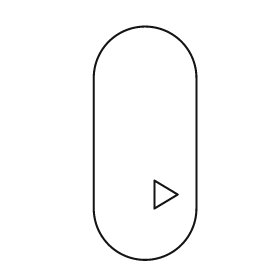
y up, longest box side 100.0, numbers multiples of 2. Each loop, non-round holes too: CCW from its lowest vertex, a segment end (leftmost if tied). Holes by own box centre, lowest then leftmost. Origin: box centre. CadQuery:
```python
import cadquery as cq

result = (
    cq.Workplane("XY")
    .moveTo(-22.0, -28.0)
    .threePointArc((0.0, -50.0), (22.0, -28.0))
    .lineTo(22.0, 28.0)
    .threePointArc((0.0, 50.0), (-22.0, 28.0))
    .close()
    .moveTo(4.0, -28.0)
    .lineTo(14.0, -22.0)
    .lineTo(4.0, -16.0)
    .close()
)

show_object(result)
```